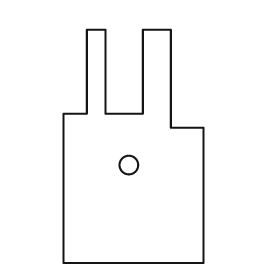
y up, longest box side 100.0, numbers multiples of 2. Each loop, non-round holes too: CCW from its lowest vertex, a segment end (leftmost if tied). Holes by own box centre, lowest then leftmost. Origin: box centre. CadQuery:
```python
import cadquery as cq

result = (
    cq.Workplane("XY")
    .moveTo(-30.0, -50.0)
    .lineTo(30.0, -50.0)
    .lineTo(30.0, 8.0)
    .lineTo(16.0, 8.0)
    .lineTo(16.0, 50.0)
    .lineTo(4.0, 50.0)
    .lineTo(4.0, 14.0)
    .lineTo(-12.0, 14.0)
    .lineTo(-12.0, 50.0)
    .lineTo(-20.0, 50.0)
    .lineTo(-20.0, 14.0)
    .lineTo(-30.0, 14.0)
    .close()
    .moveTo(-2.0, -8.0)
    .circle(4.0)
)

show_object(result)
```